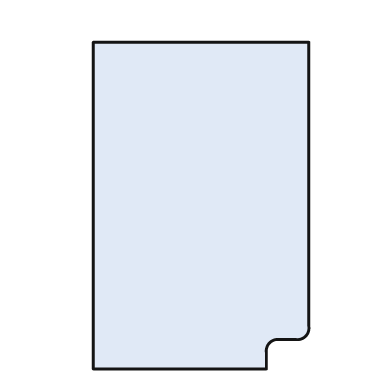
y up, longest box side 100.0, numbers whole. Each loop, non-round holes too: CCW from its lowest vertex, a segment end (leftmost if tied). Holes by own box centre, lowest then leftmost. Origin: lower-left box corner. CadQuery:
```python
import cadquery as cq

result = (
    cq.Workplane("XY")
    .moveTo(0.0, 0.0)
    .lineTo(53.0, 0.0)
    .lineTo(53.0, 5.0)
    .threePointArc((54.0, 8.0), (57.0, 9.0))
    .lineTo(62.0, 9.0)
    .threePointArc((65.0, 10.0), (66.0, 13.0))
    .lineTo(66.0, 100.0)
    .lineTo(0.0, 100.0)
    .close()
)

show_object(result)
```